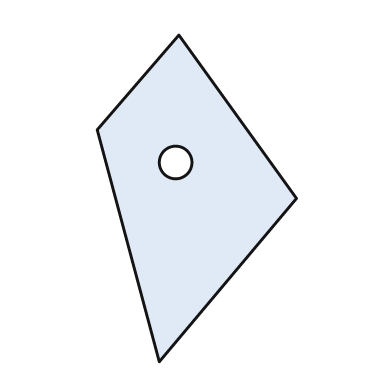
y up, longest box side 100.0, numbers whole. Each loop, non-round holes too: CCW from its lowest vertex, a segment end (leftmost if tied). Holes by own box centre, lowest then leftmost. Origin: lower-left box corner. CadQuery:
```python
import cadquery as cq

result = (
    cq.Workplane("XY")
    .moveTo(19.0, 0.0)
    .lineTo(61.0, 50.0)
    .lineTo(25.0, 100.0)
    .lineTo(0.0, 71.0)
    .close()
    .moveTo(24.0, 61.0)
    .circle(5.0)
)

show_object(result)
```